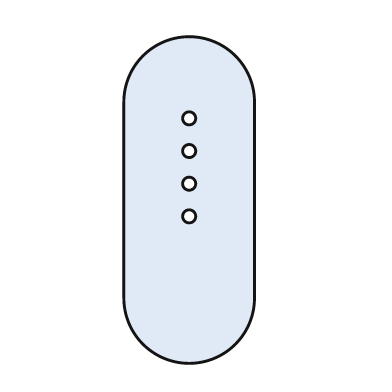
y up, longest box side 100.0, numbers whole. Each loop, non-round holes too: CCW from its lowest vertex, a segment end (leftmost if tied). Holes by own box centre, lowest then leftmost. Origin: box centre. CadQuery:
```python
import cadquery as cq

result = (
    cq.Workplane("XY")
    .moveTo(-20.0, -30.0)
    .threePointArc((0.0, -50.0), (20.0, -30.0))
    .lineTo(20.0, 30.0)
    .threePointArc((0.0, 50.0), (-20.0, 30.0))
    .close()
    .moveTo(0.0, -5.0)
    .circle(2.0)
    .moveTo(0.0, 5.0)
    .circle(2.0)
    .moveTo(0.0, 15.0)
    .circle(2.0)
    .moveTo(0.0, 25.0)
    .circle(2.0)
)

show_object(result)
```